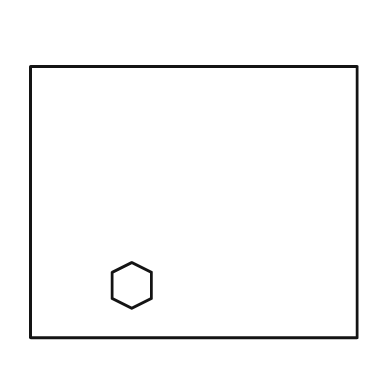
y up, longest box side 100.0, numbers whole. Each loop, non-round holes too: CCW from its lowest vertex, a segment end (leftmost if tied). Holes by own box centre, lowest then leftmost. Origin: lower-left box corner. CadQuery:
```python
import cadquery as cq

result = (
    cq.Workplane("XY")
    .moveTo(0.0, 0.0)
    .lineTo(100.0, 0.0)
    .lineTo(100.0, 83.0)
    .lineTo(0.0, 83.0)
    .close()
    .moveTo(31.0, 9.0)
    .lineTo(37.0, 12.0)
    .lineTo(37.0, 20.0)
    .lineTo(31.0, 23.0)
    .lineTo(25.0, 20.0)
    .lineTo(25.0, 12.0)
    .close()
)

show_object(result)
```